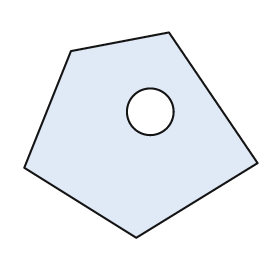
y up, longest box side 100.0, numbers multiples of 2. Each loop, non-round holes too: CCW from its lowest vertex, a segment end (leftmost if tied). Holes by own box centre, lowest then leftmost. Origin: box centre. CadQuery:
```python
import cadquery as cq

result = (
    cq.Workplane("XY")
    .moveTo(-2.0, -44.0)
    .lineTo(50.0, -12.0)
    .lineTo(12.0, 44.0)
    .lineTo(-30.0, 36.0)
    .lineTo(-50.0, -14.0)
    .close()
    .moveTo(4.0, 10.0)
    .circle(10.0)
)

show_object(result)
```